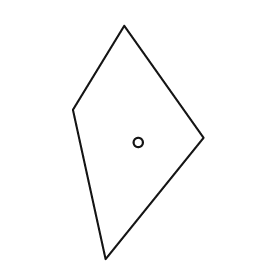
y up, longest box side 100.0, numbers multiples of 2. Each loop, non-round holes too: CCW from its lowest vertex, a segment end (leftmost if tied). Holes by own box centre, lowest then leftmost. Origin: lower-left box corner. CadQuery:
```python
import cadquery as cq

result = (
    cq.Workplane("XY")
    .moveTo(14.0, 0.0)
    .lineTo(56.0, 52.0)
    .lineTo(22.0, 100.0)
    .lineTo(0.0, 64.0)
    .close()
    .moveTo(28.0, 50.0)
    .circle(2.0)
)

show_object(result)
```